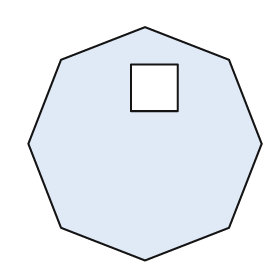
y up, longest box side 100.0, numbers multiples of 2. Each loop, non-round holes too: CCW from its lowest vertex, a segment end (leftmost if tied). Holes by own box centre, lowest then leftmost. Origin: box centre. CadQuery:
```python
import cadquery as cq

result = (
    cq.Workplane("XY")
    .moveTo(0.0, -50.0)
    .lineTo(36.0, -36.0)
    .lineTo(50.0, 0.0)
    .lineTo(36.0, 36.0)
    .lineTo(0.0, 50.0)
    .lineTo(-36.0, 36.0)
    .lineTo(-50.0, 0.0)
    .lineTo(-36.0, -36.0)
    .close()
    .moveTo(-6.0, 14.0)
    .lineTo(14.0, 14.0)
    .lineTo(14.0, 34.0)
    .lineTo(-6.0, 34.0)
    .close()
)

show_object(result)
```